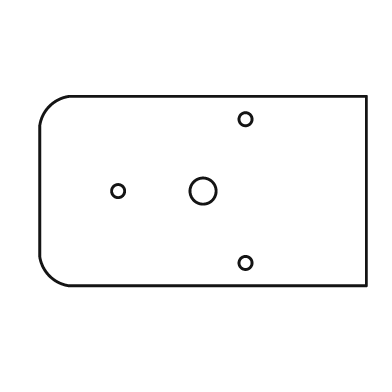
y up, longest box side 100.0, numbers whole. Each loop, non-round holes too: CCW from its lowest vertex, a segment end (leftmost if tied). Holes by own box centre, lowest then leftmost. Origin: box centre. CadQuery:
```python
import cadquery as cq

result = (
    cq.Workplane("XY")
    .moveTo(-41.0, -29.0)
    .lineTo(50.0, -29.0)
    .lineTo(50.0, 29.0)
    .lineTo(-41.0, 29.0)
    .threePointArc((-47.0, 26.0), (-50.0, 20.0))
    .lineTo(-50.0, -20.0)
    .threePointArc((-47.0, -26.0), (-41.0, -29.0))
    .close()
    .moveTo(13.0, -22.0)
    .circle(2.0)
    .moveTo(-26.0, 0.0)
    .circle(2.0)
    .moveTo(0.0, 0.0)
    .circle(4.0)
    .moveTo(13.0, 22.0)
    .circle(2.0)
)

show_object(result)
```